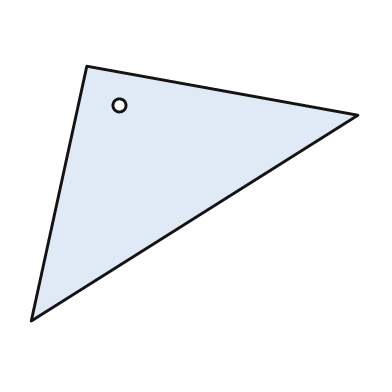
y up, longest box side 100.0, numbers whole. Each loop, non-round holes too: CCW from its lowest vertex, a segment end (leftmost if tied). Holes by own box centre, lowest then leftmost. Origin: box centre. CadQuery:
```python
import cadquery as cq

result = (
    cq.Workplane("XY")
    .moveTo(-50.0, -39.0)
    .lineTo(50.0, 24.0)
    .lineTo(-33.0, 39.0)
    .close()
    .moveTo(-23.0, 27.0)
    .circle(2.0)
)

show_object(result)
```